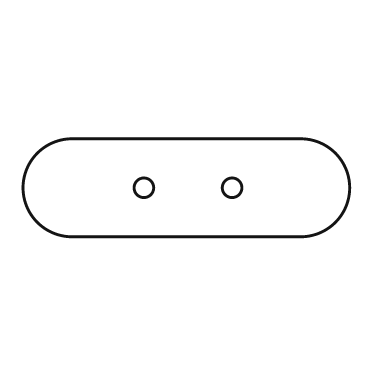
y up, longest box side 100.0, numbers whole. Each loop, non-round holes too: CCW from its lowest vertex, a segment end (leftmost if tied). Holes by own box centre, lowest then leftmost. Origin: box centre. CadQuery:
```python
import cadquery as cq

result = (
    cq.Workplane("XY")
    .moveTo(-35.0, -15.0)
    .lineTo(35.0, -15.0)
    .threePointArc((50.0, 0.0), (35.0, 15.0))
    .lineTo(-35.0, 15.0)
    .threePointArc((-50.0, 0.0), (-35.0, -15.0))
    .close()
    .moveTo(-13.0, 0.0)
    .circle(3.0)
    .moveTo(14.0, 0.0)
    .circle(3.0)
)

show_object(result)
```